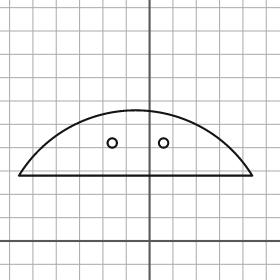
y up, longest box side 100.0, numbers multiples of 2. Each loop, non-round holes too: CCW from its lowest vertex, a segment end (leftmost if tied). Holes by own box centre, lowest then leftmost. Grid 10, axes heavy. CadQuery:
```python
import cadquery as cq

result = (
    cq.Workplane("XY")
    .moveTo(-56.0, 28.0)
    .lineTo(44.0, 28.0)
    .threePointArc((-6.0, 56.0), (-56.0, 28.0))
    .close()
    .moveTo(-16.0, 42.0)
    .circle(2.0)
    .moveTo(6.0, 42.0)
    .circle(2.0)
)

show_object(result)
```